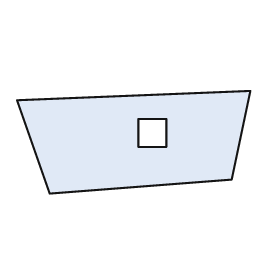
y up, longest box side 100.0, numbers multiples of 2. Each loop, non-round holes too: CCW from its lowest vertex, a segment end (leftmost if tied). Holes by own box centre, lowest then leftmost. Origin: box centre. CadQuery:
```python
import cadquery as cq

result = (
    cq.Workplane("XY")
    .moveTo(-36.0, -22.0)
    .lineTo(42.0, -16.0)
    .lineTo(50.0, 22.0)
    .lineTo(-50.0, 18.0)
    .close()
    .moveTo(2.0, -2.0)
    .lineTo(14.0, -2.0)
    .lineTo(14.0, 10.0)
    .lineTo(2.0, 10.0)
    .close()
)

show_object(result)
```